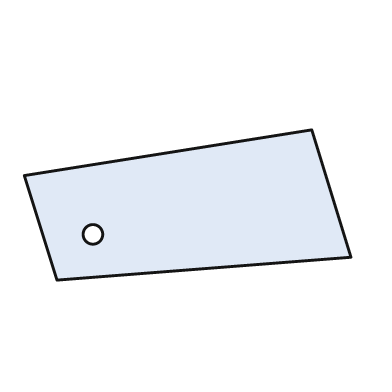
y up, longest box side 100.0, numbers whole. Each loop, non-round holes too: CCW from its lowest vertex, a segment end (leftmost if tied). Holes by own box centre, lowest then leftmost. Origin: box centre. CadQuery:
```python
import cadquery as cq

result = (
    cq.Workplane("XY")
    .moveTo(-40.0, -23.0)
    .lineTo(50.0, -16.0)
    .lineTo(38.0, 23.0)
    .lineTo(-50.0, 9.0)
    .close()
    .moveTo(-29.0, -9.0)
    .circle(3.0)
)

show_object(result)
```